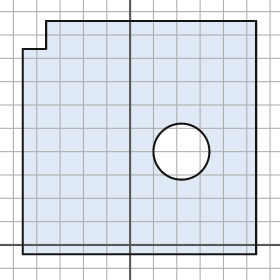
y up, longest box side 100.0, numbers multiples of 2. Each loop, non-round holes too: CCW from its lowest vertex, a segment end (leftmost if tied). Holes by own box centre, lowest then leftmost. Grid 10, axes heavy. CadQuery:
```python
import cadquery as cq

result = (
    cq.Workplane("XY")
    .moveTo(-46.0, -4.0)
    .lineTo(54.0, -4.0)
    .lineTo(54.0, 96.0)
    .lineTo(-36.0, 96.0)
    .lineTo(-36.0, 84.0)
    .lineTo(-46.0, 84.0)
    .close()
    .moveTo(22.0, 40.0)
    .circle(12.0)
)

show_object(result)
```